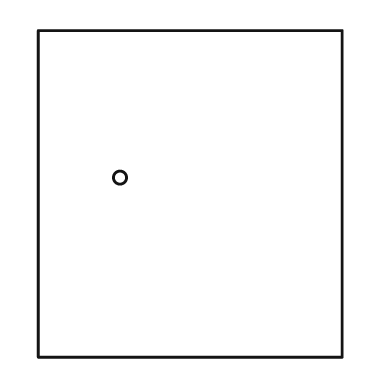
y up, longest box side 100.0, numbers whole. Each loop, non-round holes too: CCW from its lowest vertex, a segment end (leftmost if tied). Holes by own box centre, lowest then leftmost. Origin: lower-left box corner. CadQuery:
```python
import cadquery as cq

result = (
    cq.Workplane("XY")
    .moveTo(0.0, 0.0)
    .lineTo(93.0, 0.0)
    .lineTo(93.0, 100.0)
    .lineTo(0.0, 100.0)
    .close()
    .moveTo(25.0, 55.0)
    .circle(2.0)
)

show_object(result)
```